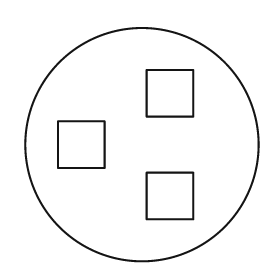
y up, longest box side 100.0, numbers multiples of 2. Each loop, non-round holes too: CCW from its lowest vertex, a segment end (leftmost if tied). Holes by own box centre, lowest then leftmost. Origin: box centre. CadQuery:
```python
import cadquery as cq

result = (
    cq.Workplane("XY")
    .moveTo(0.0, 0.0)
    .circle(50.0)
    .moveTo(2.0, -32.0)
    .lineTo(22.0, -32.0)
    .lineTo(22.0, -12.0)
    .lineTo(2.0, -12.0)
    .close()
    .moveTo(-36.0, -10.0)
    .lineTo(-16.0, -10.0)
    .lineTo(-16.0, 10.0)
    .lineTo(-36.0, 10.0)
    .close()
    .moveTo(2.0, 12.0)
    .lineTo(22.0, 12.0)
    .lineTo(22.0, 32.0)
    .lineTo(2.0, 32.0)
    .close()
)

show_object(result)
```